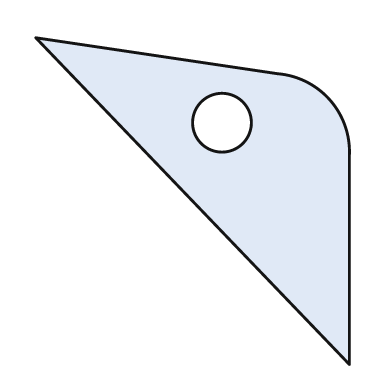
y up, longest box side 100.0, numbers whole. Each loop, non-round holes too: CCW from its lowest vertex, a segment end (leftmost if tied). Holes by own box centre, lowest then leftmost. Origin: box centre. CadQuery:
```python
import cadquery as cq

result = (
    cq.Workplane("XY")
    .moveTo(48.0, -50.0)
    .lineTo(48.0, 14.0)
    .threePointArc((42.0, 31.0), (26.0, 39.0))
    .lineTo(-48.0, 50.0)
    .close()
    .moveTo(9.0, 24.0)
    .circle(9.0)
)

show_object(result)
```